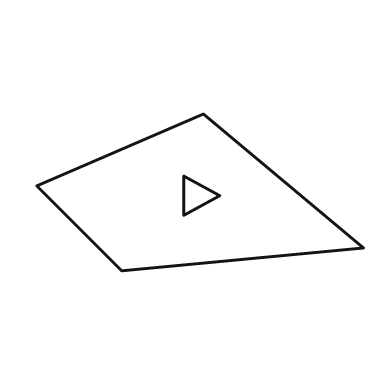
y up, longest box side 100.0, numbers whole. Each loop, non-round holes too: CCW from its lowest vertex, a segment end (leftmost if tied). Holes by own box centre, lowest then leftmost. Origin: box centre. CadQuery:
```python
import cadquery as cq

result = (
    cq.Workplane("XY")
    .moveTo(-24.0, -24.0)
    .lineTo(50.0, -17.0)
    .lineTo(1.0, 24.0)
    .lineTo(-50.0, 2.0)
    .close()
    .moveTo(-5.0, -7.0)
    .lineTo(6.0, -1.0)
    .lineTo(-5.0, 5.0)
    .close()
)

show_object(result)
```